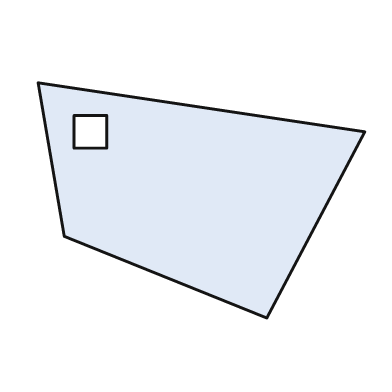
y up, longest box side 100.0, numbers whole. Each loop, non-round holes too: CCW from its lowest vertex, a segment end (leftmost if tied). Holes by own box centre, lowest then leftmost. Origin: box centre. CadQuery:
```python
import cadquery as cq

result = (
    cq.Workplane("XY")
    .moveTo(20.0, -36.0)
    .lineTo(50.0, 21.0)
    .lineTo(-50.0, 36.0)
    .lineTo(-42.0, -11.0)
    .close()
    .moveTo(-39.0, 16.0)
    .lineTo(-29.0, 16.0)
    .lineTo(-29.0, 26.0)
    .lineTo(-39.0, 26.0)
    .close()
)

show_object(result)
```